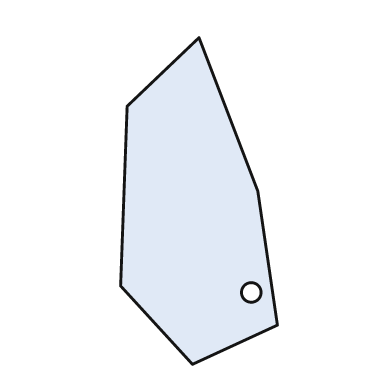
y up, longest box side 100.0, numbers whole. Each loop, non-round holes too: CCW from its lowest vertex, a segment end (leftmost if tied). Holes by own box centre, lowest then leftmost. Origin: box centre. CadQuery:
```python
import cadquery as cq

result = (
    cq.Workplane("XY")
    .moveTo(-2.0, -50.0)
    .lineTo(24.0, -38.0)
    .lineTo(18.0, 3.0)
    .lineTo(0.0, 50.0)
    .lineTo(-22.0, 29.0)
    .lineTo(-24.0, -26.0)
    .close()
    .moveTo(16.0, -28.0)
    .circle(3.0)
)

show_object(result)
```